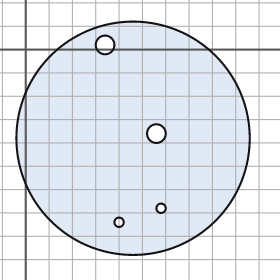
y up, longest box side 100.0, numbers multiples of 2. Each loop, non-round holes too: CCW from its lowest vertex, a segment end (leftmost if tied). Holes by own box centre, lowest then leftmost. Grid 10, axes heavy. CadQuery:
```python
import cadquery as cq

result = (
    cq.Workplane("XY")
    .moveTo(46.0, -38.0)
    .circle(50.0)
    .moveTo(40.0, -74.0)
    .circle(2.0)
    .moveTo(58.0, -68.0)
    .circle(2.0)
    .moveTo(56.0, -36.0)
    .circle(4.0)
    .moveTo(34.0, 2.0)
    .circle(4.0)
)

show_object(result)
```